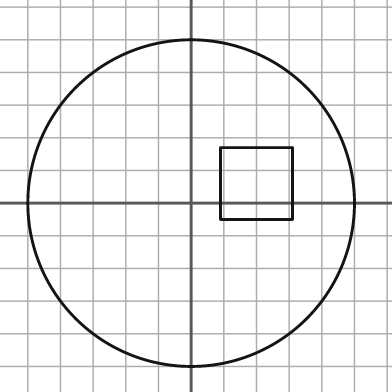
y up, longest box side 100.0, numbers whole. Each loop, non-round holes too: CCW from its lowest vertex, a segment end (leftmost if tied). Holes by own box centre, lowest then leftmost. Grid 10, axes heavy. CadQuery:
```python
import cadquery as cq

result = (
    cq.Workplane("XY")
    .moveTo(0.0, 0.0)
    .circle(50.0)
    .moveTo(9.0, -5.0)
    .lineTo(31.0, -5.0)
    .lineTo(31.0, 17.0)
    .lineTo(9.0, 17.0)
    .close()
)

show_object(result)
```